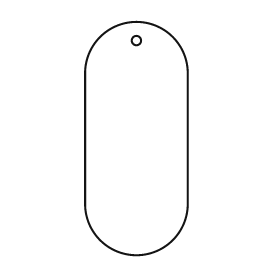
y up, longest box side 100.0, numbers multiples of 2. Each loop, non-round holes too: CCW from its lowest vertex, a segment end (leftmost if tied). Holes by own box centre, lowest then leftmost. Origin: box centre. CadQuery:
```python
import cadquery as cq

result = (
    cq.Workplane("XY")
    .moveTo(-22.0, -28.0)
    .threePointArc((0.0, -50.0), (22.0, -28.0))
    .lineTo(22.0, 28.0)
    .threePointArc((0.0, 50.0), (-22.0, 28.0))
    .close()
    .moveTo(0.0, 42.0)
    .circle(2.0)
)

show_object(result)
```